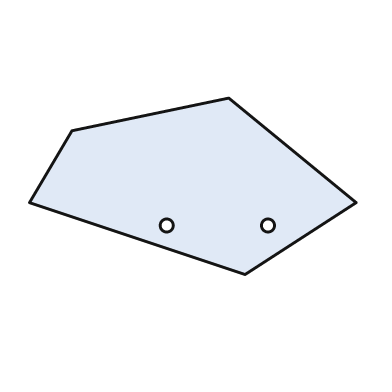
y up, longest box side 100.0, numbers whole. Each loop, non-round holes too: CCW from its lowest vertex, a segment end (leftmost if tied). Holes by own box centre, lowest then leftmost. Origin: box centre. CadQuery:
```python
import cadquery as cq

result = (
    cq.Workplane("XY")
    .moveTo(16.0, -27.0)
    .lineTo(50.0, -5.0)
    .lineTo(11.0, 27.0)
    .lineTo(-37.0, 17.0)
    .lineTo(-50.0, -5.0)
    .close()
    .moveTo(-8.0, -12.0)
    .circle(2.0)
    .moveTo(23.0, -12.0)
    .circle(2.0)
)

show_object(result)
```